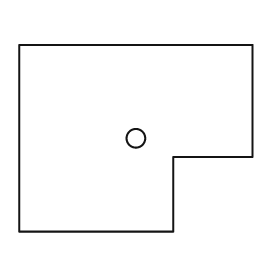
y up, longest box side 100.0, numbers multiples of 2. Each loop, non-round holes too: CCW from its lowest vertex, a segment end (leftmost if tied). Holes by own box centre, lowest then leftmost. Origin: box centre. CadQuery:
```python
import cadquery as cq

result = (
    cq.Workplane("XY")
    .moveTo(-50.0, -40.0)
    .lineTo(16.0, -40.0)
    .lineTo(16.0, -8.0)
    .lineTo(50.0, -8.0)
    .lineTo(50.0, 40.0)
    .lineTo(-50.0, 40.0)
    .close()
    .moveTo(0.0, 0.0)
    .circle(4.0)
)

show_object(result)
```